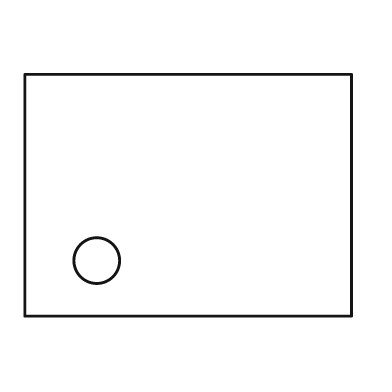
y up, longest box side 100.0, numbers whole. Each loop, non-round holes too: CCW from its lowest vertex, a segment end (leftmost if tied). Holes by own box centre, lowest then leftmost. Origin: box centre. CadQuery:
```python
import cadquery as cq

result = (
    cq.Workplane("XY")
    .moveTo(-50.0, -37.0)
    .lineTo(50.0, -37.0)
    .lineTo(50.0, 37.0)
    .lineTo(-50.0, 37.0)
    .close()
    .moveTo(-28.0, -20.0)
    .circle(7.0)
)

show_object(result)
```